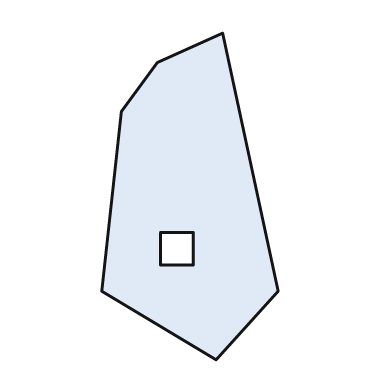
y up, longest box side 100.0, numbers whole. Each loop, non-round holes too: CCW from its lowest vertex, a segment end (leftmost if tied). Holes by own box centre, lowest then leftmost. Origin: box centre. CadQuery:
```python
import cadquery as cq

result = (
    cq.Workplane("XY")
    .moveTo(8.0, -50.0)
    .lineTo(27.0, -29.0)
    .lineTo(10.0, 50.0)
    .lineTo(-10.0, 41.0)
    .lineTo(-21.0, 26.0)
    .lineTo(-27.0, -29.0)
    .close()
    .moveTo(-9.0, -21.0)
    .lineTo(1.0, -21.0)
    .lineTo(1.0, -11.0)
    .lineTo(-9.0, -11.0)
    .close()
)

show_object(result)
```